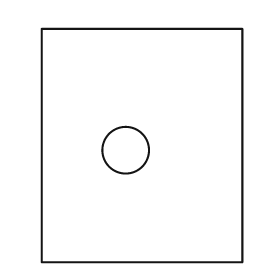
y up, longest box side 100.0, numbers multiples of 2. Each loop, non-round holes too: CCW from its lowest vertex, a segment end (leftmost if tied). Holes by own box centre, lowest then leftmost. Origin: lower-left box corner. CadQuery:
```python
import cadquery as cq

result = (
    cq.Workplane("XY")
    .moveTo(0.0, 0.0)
    .lineTo(86.0, 0.0)
    .lineTo(86.0, 100.0)
    .lineTo(0.0, 100.0)
    .close()
    .moveTo(36.0, 48.0)
    .circle(10.0)
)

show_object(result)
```